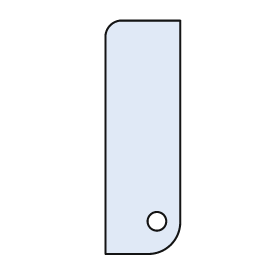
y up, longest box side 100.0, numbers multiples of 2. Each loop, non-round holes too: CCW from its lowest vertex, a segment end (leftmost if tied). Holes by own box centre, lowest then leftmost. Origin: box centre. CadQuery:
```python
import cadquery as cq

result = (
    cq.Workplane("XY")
    .moveTo(-16.0, -50.0)
    .lineTo(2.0, -50.0)
    .threePointArc((12.0, -46.0), (16.0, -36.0))
    .lineTo(16.0, 50.0)
    .lineTo(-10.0, 50.0)
    .threePointArc((-14.0, 48.0), (-16.0, 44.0))
    .close()
    .moveTo(6.0, -36.0)
    .circle(4.0)
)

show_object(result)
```